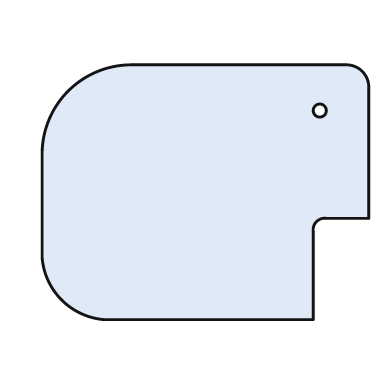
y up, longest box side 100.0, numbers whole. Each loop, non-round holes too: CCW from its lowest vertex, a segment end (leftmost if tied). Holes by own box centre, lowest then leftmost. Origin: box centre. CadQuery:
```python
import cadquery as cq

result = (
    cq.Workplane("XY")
    .moveTo(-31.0, -39.0)
    .lineTo(33.0, -39.0)
    .lineTo(33.0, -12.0)
    .threePointArc((34.0, -9.0), (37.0, -8.0))
    .lineTo(50.0, -8.0)
    .lineTo(50.0, 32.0)
    .threePointArc((48.0, 37.0), (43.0, 39.0))
    .lineTo(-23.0, 39.0)
    .threePointArc((-42.0, 31.0), (-50.0, 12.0))
    .lineTo(-50.0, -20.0)
    .threePointArc((-44.0, -33.0), (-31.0, -39.0))
    .close()
    .moveTo(35.0, 25.0)
    .circle(2.0)
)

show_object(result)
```